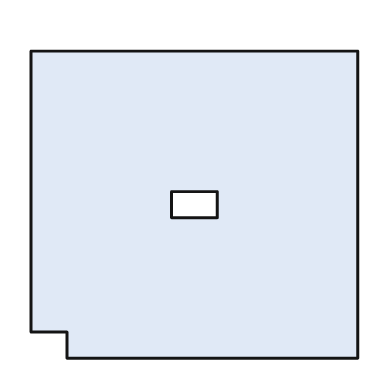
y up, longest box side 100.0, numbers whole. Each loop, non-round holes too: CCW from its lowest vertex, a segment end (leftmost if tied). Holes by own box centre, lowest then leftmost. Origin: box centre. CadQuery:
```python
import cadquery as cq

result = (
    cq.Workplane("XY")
    .moveTo(-39.0, -47.0)
    .lineTo(50.0, -47.0)
    .lineTo(50.0, 47.0)
    .lineTo(-50.0, 47.0)
    .lineTo(-50.0, -39.0)
    .lineTo(-39.0, -39.0)
    .close()
    .moveTo(-7.0, -4.0)
    .lineTo(7.0, -4.0)
    .lineTo(7.0, 4.0)
    .lineTo(-7.0, 4.0)
    .close()
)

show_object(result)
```